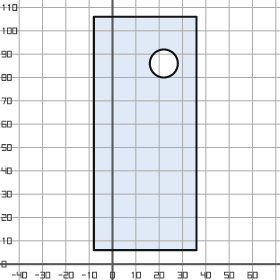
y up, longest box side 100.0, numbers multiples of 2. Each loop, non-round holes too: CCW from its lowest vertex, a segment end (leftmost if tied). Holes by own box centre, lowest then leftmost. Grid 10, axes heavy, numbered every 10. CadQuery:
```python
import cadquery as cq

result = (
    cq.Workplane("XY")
    .moveTo(-8.0, 6.0)
    .lineTo(36.0, 6.0)
    .lineTo(36.0, 106.0)
    .lineTo(-8.0, 106.0)
    .close()
    .moveTo(22.0, 86.0)
    .circle(6.0)
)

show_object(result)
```